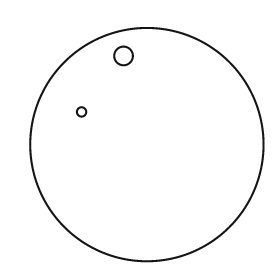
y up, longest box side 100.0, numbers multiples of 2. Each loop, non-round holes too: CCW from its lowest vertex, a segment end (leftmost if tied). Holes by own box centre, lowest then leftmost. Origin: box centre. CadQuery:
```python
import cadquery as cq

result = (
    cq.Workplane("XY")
    .moveTo(0.0, 0.0)
    .circle(50.0)
    .moveTo(-28.0, 14.0)
    .circle(2.0)
    .moveTo(-10.0, 38.0)
    .circle(4.0)
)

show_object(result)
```